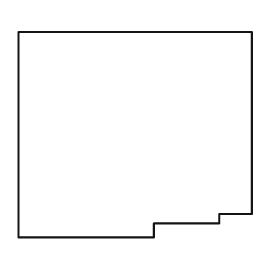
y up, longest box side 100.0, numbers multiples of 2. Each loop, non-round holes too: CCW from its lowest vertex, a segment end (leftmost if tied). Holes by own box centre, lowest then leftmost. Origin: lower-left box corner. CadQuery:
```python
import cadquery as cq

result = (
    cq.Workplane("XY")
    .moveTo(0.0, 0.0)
    .lineTo(58.0, 0.0)
    .lineTo(58.0, 6.0)
    .lineTo(86.0, 6.0)
    .lineTo(86.0, 10.0)
    .lineTo(100.0, 10.0)
    .lineTo(100.0, 88.0)
    .lineTo(0.0, 88.0)
    .close()
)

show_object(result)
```